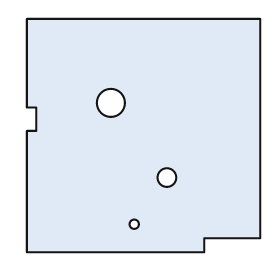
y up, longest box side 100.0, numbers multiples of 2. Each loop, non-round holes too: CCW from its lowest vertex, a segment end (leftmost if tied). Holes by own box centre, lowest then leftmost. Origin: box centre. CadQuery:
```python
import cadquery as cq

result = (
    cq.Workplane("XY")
    .moveTo(-50.0, -50.0)
    .lineTo(26.0, -50.0)
    .lineTo(26.0, -44.0)
    .lineTo(50.0, -44.0)
    .lineTo(50.0, 50.0)
    .lineTo(-50.0, 50.0)
    .lineTo(-50.0, 12.0)
    .lineTo(-46.0, 12.0)
    .lineTo(-46.0, 2.0)
    .lineTo(-50.0, 2.0)
    .close()
    .moveTo(-4.0, -38.0)
    .circle(2.0)
    .moveTo(10.0, -18.0)
    .circle(4.0)
    .moveTo(-14.0, 14.0)
    .circle(6.0)
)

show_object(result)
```